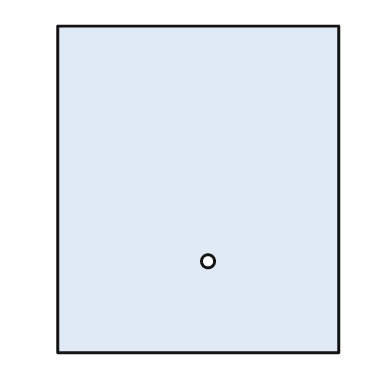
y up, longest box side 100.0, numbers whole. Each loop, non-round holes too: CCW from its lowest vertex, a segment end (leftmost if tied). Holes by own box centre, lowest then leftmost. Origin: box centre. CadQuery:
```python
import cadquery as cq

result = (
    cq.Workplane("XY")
    .moveTo(-43.0, -50.0)
    .lineTo(43.0, -50.0)
    .lineTo(43.0, 50.0)
    .lineTo(-43.0, 50.0)
    .close()
    .moveTo(3.0, -22.0)
    .circle(2.0)
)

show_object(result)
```